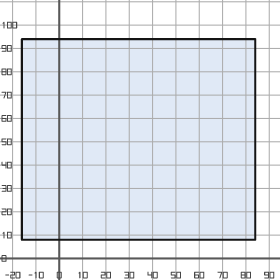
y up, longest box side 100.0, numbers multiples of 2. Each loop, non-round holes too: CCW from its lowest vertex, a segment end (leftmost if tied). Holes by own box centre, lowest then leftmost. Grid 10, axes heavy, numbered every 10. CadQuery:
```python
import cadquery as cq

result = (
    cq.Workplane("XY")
    .moveTo(-16.0, 8.0)
    .lineTo(84.0, 8.0)
    .lineTo(84.0, 94.0)
    .lineTo(-16.0, 94.0)
    .close()
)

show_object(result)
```